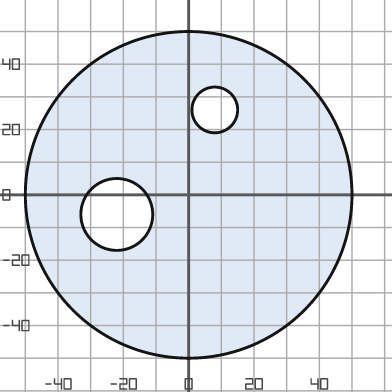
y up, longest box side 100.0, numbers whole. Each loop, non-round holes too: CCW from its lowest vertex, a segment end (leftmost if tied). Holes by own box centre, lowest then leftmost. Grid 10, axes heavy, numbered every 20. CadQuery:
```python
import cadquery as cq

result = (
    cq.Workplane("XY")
    .moveTo(0.0, 0.0)
    .circle(50.0)
    .moveTo(-22.0, -6.0)
    .circle(11.0)
    .moveTo(8.0, 26.0)
    .circle(7.0)
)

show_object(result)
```